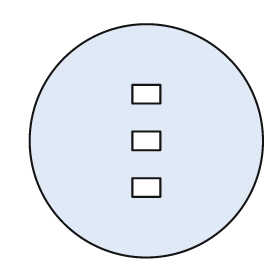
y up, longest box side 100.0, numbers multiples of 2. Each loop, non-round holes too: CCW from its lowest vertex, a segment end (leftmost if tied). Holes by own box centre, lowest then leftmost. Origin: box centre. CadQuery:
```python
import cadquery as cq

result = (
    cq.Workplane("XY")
    .moveTo(0.0, 0.0)
    .circle(50.0)
    .moveTo(-6.0, -24.0)
    .lineTo(6.0, -24.0)
    .lineTo(6.0, -16.0)
    .lineTo(-6.0, -16.0)
    .close()
    .moveTo(-6.0, -4.0)
    .lineTo(6.0, -4.0)
    .lineTo(6.0, 4.0)
    .lineTo(-6.0, 4.0)
    .close()
    .moveTo(-6.0, 16.0)
    .lineTo(6.0, 16.0)
    .lineTo(6.0, 24.0)
    .lineTo(-6.0, 24.0)
    .close()
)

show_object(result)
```